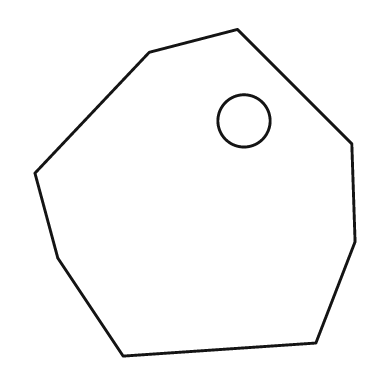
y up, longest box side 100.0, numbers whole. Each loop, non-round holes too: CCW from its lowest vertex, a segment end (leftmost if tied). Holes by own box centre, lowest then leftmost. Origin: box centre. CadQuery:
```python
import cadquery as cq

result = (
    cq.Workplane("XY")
    .moveTo(-22.0, -50.0)
    .lineTo(37.0, -46.0)
    .lineTo(49.0, -15.0)
    .lineTo(48.0, 15.0)
    .lineTo(13.0, 50.0)
    .lineTo(-14.0, 43.0)
    .lineTo(-49.0, 6.0)
    .lineTo(-42.0, -20.0)
    .close()
    .moveTo(15.0, 22.0)
    .circle(8.0)
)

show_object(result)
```